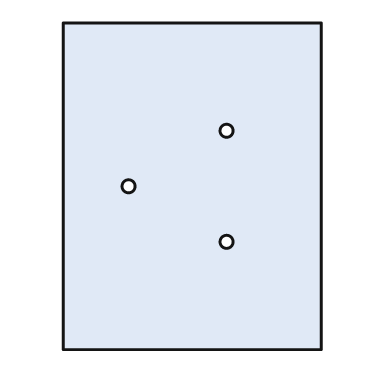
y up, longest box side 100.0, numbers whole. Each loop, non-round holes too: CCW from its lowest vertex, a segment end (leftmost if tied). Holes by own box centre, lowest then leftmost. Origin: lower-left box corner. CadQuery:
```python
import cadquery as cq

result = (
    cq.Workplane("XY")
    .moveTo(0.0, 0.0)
    .lineTo(79.0, 0.0)
    .lineTo(79.0, 100.0)
    .lineTo(0.0, 100.0)
    .close()
    .moveTo(50.0, 33.0)
    .circle(2.0)
    .moveTo(20.0, 50.0)
    .circle(2.0)
    .moveTo(50.0, 67.0)
    .circle(2.0)
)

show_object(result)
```